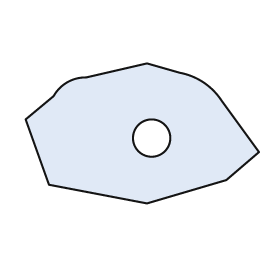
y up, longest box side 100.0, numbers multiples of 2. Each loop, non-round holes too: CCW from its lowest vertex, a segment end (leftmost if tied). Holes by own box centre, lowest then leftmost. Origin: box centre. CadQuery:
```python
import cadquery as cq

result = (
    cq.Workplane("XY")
    .moveTo(2.0, -30.0)
    .lineTo(36.0, -20.0)
    .lineTo(50.0, -8.0)
    .lineTo(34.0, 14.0)
    .threePointArc((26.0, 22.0), (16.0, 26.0))
    .lineTo(2.0, 30.0)
    .lineTo(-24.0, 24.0)
    .threePointArc((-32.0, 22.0), (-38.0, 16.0))
    .lineTo(-50.0, 6.0)
    .lineTo(-40.0, -22.0)
    .close()
    .moveTo(4.0, -2.0)
    .circle(8.0)
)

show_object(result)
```